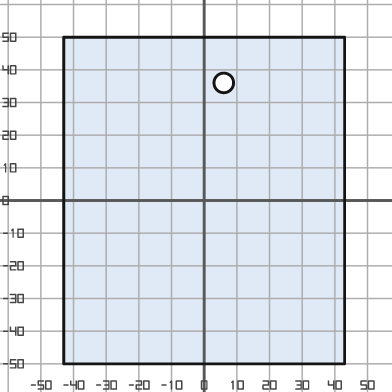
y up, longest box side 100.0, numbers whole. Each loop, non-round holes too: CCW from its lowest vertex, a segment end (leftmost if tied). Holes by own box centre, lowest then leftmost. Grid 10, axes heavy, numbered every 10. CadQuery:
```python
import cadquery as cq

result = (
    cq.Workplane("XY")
    .moveTo(-43.0, -50.0)
    .lineTo(43.0, -50.0)
    .lineTo(43.0, 50.0)
    .lineTo(-43.0, 50.0)
    .close()
    .moveTo(6.0, 36.0)
    .circle(3.0)
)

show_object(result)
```